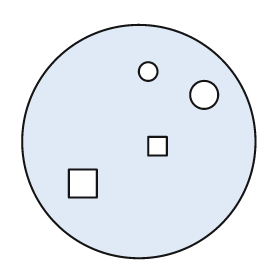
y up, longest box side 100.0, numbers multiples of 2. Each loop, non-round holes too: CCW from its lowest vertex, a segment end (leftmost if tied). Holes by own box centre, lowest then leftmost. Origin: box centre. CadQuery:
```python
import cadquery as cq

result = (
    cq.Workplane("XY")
    .moveTo(0.0, 0.0)
    .circle(50.0)
    .moveTo(-30.0, -24.0)
    .lineTo(-18.0, -24.0)
    .lineTo(-18.0, -12.0)
    .lineTo(-30.0, -12.0)
    .close()
    .moveTo(4.0, -6.0)
    .lineTo(12.0, -6.0)
    .lineTo(12.0, 2.0)
    .lineTo(4.0, 2.0)
    .close()
    .moveTo(28.0, 20.0)
    .circle(6.0)
    .moveTo(4.0, 30.0)
    .circle(4.0)
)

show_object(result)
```